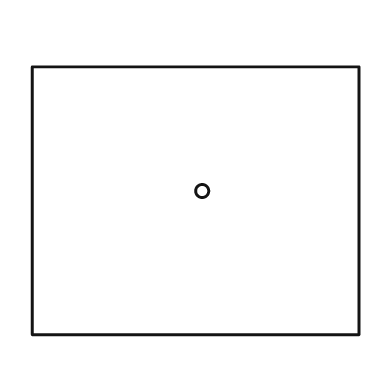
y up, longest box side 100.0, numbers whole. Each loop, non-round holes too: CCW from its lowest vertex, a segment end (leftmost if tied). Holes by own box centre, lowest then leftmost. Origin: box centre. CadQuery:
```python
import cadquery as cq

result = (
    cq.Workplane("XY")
    .moveTo(-50.0, -41.0)
    .lineTo(50.0, -41.0)
    .lineTo(50.0, 41.0)
    .lineTo(-50.0, 41.0)
    .close()
    .moveTo(2.0, 3.0)
    .circle(2.0)
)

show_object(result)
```